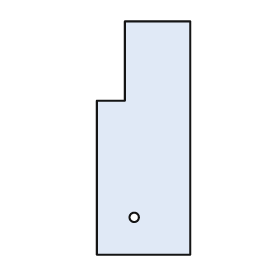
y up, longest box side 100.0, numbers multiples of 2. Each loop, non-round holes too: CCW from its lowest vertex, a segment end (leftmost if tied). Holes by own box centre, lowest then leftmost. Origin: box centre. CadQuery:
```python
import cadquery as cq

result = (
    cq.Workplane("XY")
    .moveTo(-20.0, -50.0)
    .lineTo(20.0, -50.0)
    .lineTo(20.0, 50.0)
    .lineTo(-8.0, 50.0)
    .lineTo(-8.0, 16.0)
    .lineTo(-20.0, 16.0)
    .close()
    .moveTo(-4.0, -34.0)
    .circle(2.0)
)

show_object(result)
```